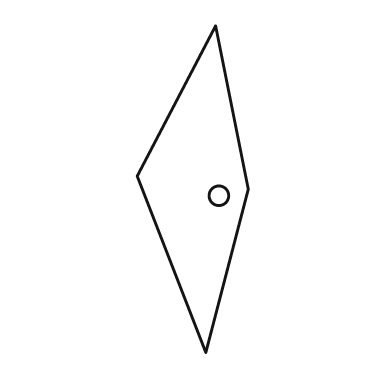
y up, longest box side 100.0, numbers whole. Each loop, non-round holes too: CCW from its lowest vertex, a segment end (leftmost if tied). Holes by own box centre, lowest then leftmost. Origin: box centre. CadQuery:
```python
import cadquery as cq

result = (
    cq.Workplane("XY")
    .moveTo(4.0, -50.0)
    .lineTo(17.0, 0.0)
    .lineTo(7.0, 50.0)
    .lineTo(-17.0, 4.0)
    .close()
    .moveTo(8.0, -2.0)
    .circle(3.0)
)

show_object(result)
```